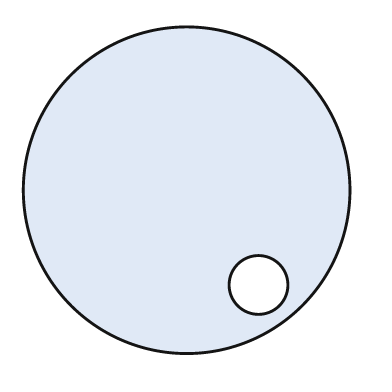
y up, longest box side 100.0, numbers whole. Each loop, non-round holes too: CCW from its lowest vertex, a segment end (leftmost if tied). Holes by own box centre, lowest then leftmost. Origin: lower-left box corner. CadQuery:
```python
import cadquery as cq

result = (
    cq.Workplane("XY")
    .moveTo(50.0, 50.0)
    .circle(50.0)
    .moveTo(72.0, 21.0)
    .circle(9.0)
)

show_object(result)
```